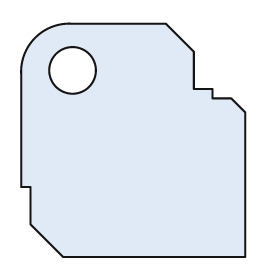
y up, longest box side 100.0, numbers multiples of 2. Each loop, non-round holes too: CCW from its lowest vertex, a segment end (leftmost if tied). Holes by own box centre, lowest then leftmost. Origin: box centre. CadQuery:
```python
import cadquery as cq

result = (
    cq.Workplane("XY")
    .moveTo(-30.0, -50.0)
    .lineTo(48.0, -50.0)
    .lineTo(48.0, 12.0)
    .lineTo(42.0, 18.0)
    .lineTo(34.0, 18.0)
    .lineTo(34.0, 22.0)
    .lineTo(26.0, 22.0)
    .lineTo(26.0, 38.0)
    .lineTo(14.0, 50.0)
    .lineTo(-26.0, 50.0)
    .threePointArc((-42.0, 44.0), (-48.0, 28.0))
    .lineTo(-48.0, -20.0)
    .lineTo(-44.0, -20.0)
    .lineTo(-44.0, -36.0)
    .close()
    .moveTo(-26.0, 30.0)
    .circle(10.0)
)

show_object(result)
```